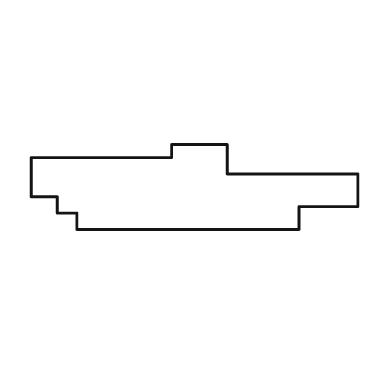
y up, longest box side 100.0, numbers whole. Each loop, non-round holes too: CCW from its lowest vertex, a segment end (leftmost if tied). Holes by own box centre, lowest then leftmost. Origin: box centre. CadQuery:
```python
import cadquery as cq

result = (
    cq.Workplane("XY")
    .moveTo(-36.0, -13.0)
    .lineTo(32.0, -13.0)
    .lineTo(32.0, -6.0)
    .lineTo(50.0, -6.0)
    .lineTo(50.0, 4.0)
    .lineTo(10.0, 4.0)
    .lineTo(10.0, 13.0)
    .lineTo(-7.0, 13.0)
    .lineTo(-7.0, 9.0)
    .lineTo(-50.0, 9.0)
    .lineTo(-50.0, -3.0)
    .lineTo(-42.0, -3.0)
    .lineTo(-42.0, -8.0)
    .lineTo(-36.0, -8.0)
    .close()
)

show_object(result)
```